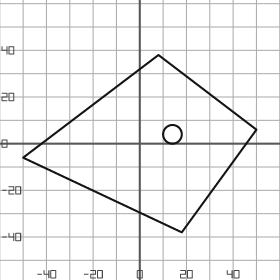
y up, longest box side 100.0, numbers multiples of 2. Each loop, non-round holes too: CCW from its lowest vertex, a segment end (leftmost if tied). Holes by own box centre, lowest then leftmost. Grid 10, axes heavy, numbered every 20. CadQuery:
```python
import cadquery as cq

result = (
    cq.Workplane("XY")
    .moveTo(18.0, -38.0)
    .lineTo(50.0, 6.0)
    .lineTo(8.0, 38.0)
    .lineTo(-50.0, -6.0)
    .close()
    .moveTo(14.0, 4.0)
    .circle(4.0)
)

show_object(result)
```